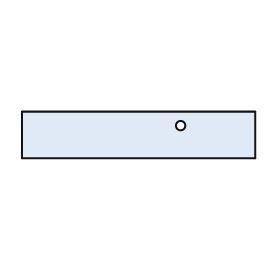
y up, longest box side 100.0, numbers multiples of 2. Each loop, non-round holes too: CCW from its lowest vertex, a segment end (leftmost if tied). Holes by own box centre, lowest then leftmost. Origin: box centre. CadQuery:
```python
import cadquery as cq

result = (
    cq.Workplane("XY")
    .moveTo(-50.0, -10.0)
    .lineTo(50.0, -10.0)
    .lineTo(50.0, 10.0)
    .lineTo(-50.0, 10.0)
    .close()
    .moveTo(18.0, 4.0)
    .circle(2.0)
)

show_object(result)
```